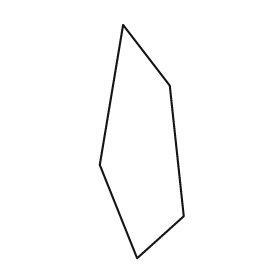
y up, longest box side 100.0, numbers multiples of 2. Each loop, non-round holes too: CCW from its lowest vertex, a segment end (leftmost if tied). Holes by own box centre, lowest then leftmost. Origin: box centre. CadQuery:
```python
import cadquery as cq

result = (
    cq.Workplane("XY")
    .moveTo(-2.0, -50.0)
    .lineTo(18.0, -32.0)
    .lineTo(12.0, 24.0)
    .lineTo(-8.0, 50.0)
    .lineTo(-18.0, -10.0)
    .close()
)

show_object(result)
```